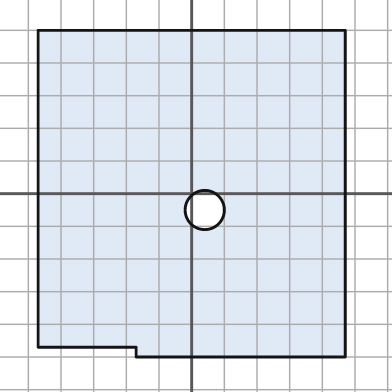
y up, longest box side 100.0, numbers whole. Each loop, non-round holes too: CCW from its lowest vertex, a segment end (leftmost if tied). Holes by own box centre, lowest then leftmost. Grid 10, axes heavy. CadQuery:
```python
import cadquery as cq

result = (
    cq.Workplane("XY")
    .moveTo(-17.0, -50.0)
    .lineTo(47.0, -50.0)
    .lineTo(47.0, 50.0)
    .lineTo(-47.0, 50.0)
    .lineTo(-47.0, -47.0)
    .lineTo(-17.0, -47.0)
    .close()
    .moveTo(4.0, -5.0)
    .circle(6.0)
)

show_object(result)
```